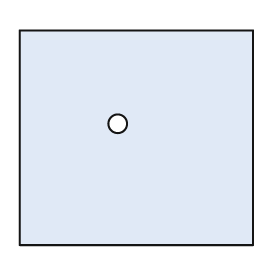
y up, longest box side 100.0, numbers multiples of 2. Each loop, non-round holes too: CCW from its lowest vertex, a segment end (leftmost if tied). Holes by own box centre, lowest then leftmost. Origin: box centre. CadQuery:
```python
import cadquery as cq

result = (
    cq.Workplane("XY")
    .moveTo(-50.0, -46.0)
    .lineTo(50.0, -46.0)
    .lineTo(50.0, 46.0)
    .lineTo(-50.0, 46.0)
    .close()
    .moveTo(-8.0, 6.0)
    .circle(4.0)
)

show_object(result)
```